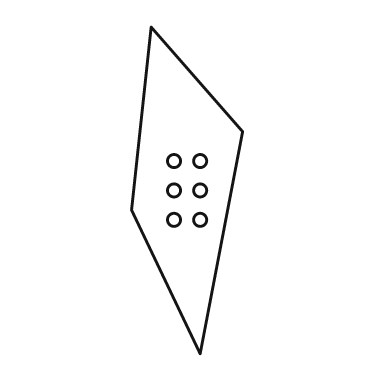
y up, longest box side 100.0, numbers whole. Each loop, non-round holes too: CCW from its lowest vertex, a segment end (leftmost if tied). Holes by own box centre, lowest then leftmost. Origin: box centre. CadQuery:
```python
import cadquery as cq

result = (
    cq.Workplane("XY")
    .moveTo(4.0, -50.0)
    .lineTo(17.0, 18.0)
    .lineTo(-11.0, 50.0)
    .lineTo(-17.0, -6.0)
    .close()
    .moveTo(-4.0, -9.0)
    .circle(2.0)
    .moveTo(4.0, -9.0)
    .circle(2.0)
    .moveTo(-4.0, 0.0)
    .circle(2.0)
    .moveTo(4.0, 0.0)
    .circle(2.0)
    .moveTo(-4.0, 9.0)
    .circle(2.0)
    .moveTo(4.0, 9.0)
    .circle(2.0)
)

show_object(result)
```